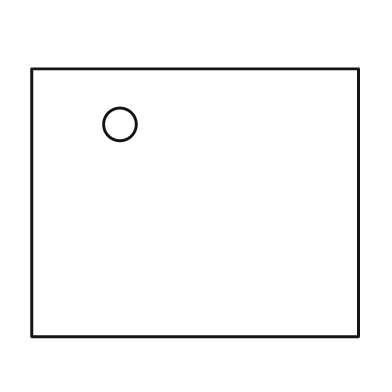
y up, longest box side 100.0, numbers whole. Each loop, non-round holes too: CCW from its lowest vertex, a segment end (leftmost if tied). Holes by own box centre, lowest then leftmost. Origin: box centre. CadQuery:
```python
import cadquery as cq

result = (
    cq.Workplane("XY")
    .moveTo(-50.0, -41.0)
    .lineTo(50.0, -41.0)
    .lineTo(50.0, 41.0)
    .lineTo(-50.0, 41.0)
    .close()
    .moveTo(-23.0, 24.0)
    .circle(5.0)
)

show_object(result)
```